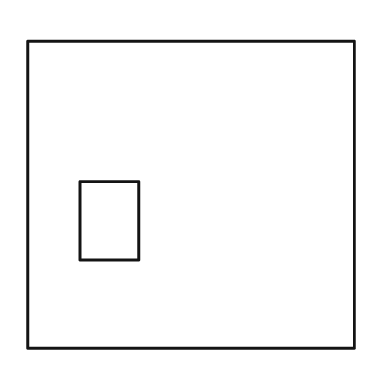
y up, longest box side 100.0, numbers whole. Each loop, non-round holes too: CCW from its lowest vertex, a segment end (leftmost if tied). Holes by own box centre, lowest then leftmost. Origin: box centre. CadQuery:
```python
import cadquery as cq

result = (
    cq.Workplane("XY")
    .moveTo(-50.0, -47.0)
    .lineTo(50.0, -47.0)
    .lineTo(50.0, 47.0)
    .lineTo(-50.0, 47.0)
    .close()
    .moveTo(-34.0, -20.0)
    .lineTo(-16.0, -20.0)
    .lineTo(-16.0, 4.0)
    .lineTo(-34.0, 4.0)
    .close()
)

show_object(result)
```